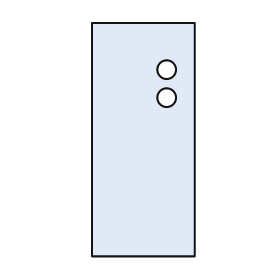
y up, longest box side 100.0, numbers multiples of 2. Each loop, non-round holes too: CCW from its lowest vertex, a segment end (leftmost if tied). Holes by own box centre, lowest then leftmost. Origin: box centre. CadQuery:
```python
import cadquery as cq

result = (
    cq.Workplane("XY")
    .moveTo(-22.0, -50.0)
    .lineTo(22.0, -50.0)
    .lineTo(22.0, 50.0)
    .lineTo(-22.0, 50.0)
    .close()
    .moveTo(10.0, 18.0)
    .circle(4.0)
    .moveTo(10.0, 30.0)
    .circle(4.0)
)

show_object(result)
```